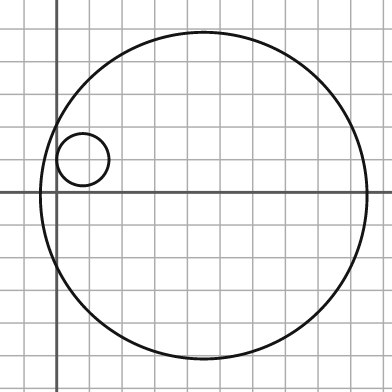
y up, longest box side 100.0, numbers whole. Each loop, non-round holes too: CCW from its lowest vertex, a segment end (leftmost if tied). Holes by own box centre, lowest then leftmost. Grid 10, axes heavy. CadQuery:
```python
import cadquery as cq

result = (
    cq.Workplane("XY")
    .moveTo(45.0, -1.0)
    .circle(50.0)
    .moveTo(8.0, 10.0)
    .circle(8.0)
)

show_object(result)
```